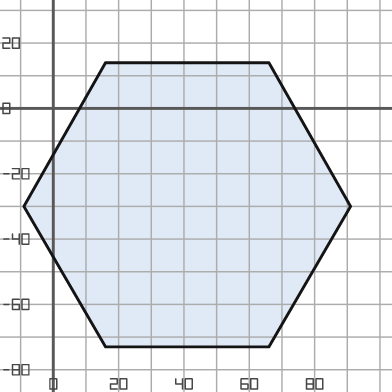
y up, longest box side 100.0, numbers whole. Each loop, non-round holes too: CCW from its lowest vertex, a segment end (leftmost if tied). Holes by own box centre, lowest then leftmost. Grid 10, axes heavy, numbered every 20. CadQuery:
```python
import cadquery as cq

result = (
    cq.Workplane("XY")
    .moveTo(16.0, -73.0)
    .lineTo(66.0, -73.0)
    .lineTo(91.0, -30.0)
    .lineTo(66.0, 14.0)
    .lineTo(16.0, 14.0)
    .lineTo(-9.0, -30.0)
    .close()
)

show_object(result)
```